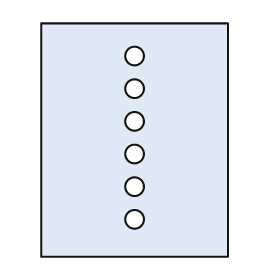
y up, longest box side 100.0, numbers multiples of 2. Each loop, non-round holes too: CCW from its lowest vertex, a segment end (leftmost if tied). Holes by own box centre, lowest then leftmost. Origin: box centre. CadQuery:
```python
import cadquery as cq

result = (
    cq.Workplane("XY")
    .moveTo(-40.0, -50.0)
    .lineTo(40.0, -50.0)
    .lineTo(40.0, 50.0)
    .lineTo(-40.0, 50.0)
    .close()
    .moveTo(0.0, -34.0)
    .circle(4.0)
    .moveTo(0.0, -20.0)
    .circle(4.0)
    .moveTo(0.0, -6.0)
    .circle(4.0)
    .moveTo(0.0, 8.0)
    .circle(4.0)
    .moveTo(0.0, 22.0)
    .circle(4.0)
    .moveTo(0.0, 36.0)
    .circle(4.0)
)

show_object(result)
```